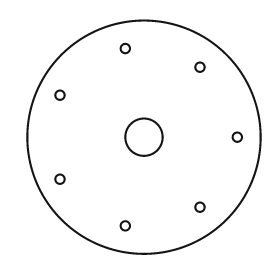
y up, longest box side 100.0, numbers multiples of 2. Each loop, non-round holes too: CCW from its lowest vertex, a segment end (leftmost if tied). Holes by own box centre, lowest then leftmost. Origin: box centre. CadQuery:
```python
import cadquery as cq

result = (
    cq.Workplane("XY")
    .moveTo(0.0, 0.0)
    .circle(50.0)
    .moveTo(-8.0, -38.0)
    .circle(2.0)
    .moveTo(24.0, -30.0)
    .circle(2.0)
    .moveTo(-36.0, -18.0)
    .circle(2.0)
    .moveTo(0.0, 0.0)
    .circle(8.0)
    .moveTo(40.0, 0.0)
    .circle(2.0)
    .moveTo(-36.0, 18.0)
    .circle(2.0)
    .moveTo(24.0, 30.0)
    .circle(2.0)
    .moveTo(-8.0, 38.0)
    .circle(2.0)
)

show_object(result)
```